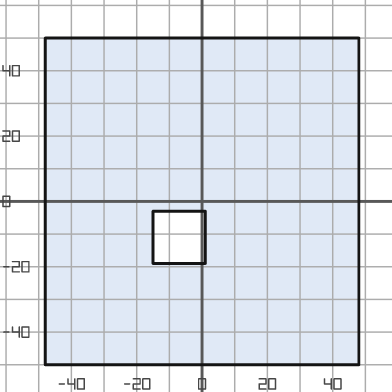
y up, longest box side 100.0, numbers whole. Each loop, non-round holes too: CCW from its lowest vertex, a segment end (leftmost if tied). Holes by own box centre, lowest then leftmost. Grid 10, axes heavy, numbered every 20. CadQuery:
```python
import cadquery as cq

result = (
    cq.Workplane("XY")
    .moveTo(-48.0, -50.0)
    .lineTo(48.0, -50.0)
    .lineTo(48.0, 50.0)
    .lineTo(-48.0, 50.0)
    .close()
    .moveTo(-15.0, -19.0)
    .lineTo(1.0, -19.0)
    .lineTo(1.0, -3.0)
    .lineTo(-15.0, -3.0)
    .close()
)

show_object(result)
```